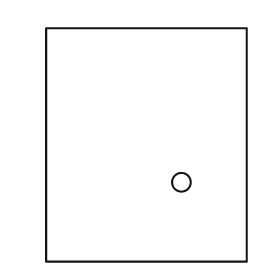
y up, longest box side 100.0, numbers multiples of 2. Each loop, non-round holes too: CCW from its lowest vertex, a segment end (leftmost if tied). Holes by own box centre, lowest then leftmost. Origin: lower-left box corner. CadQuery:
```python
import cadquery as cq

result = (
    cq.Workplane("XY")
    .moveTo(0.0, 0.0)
    .lineTo(86.0, 0.0)
    .lineTo(86.0, 100.0)
    .lineTo(0.0, 100.0)
    .close()
    .moveTo(58.0, 34.0)
    .circle(4.0)
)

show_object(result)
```